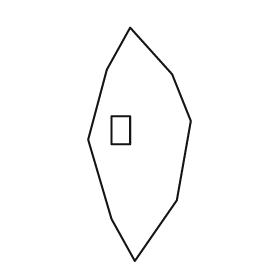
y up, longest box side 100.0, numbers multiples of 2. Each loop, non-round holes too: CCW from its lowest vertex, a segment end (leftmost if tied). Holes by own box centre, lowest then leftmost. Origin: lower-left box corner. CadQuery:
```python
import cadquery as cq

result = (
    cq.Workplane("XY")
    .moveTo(20.0, 0.0)
    .lineTo(38.0, 26.0)
    .lineTo(44.0, 60.0)
    .lineTo(36.0, 80.0)
    .lineTo(18.0, 100.0)
    .lineTo(8.0, 82.0)
    .lineTo(0.0, 52.0)
    .lineTo(10.0, 18.0)
    .close()
    .moveTo(10.0, 50.0)
    .lineTo(18.0, 50.0)
    .lineTo(18.0, 62.0)
    .lineTo(10.0, 62.0)
    .close()
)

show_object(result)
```